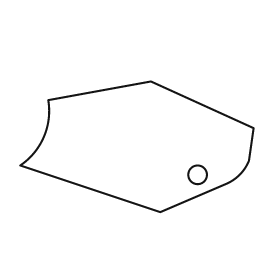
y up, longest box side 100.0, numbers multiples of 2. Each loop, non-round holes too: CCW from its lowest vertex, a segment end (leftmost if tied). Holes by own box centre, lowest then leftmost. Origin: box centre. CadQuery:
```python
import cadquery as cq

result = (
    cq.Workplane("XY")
    .moveTo(10.0, -28.0)
    .lineTo(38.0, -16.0)
    .threePointArc((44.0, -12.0), (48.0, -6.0))
    .lineTo(50.0, 8.0)
    .lineTo(6.0, 28.0)
    .lineTo(-38.0, 20.0)
    .threePointArc((-40.0, 4.0), (-50.0, -8.0))
    .close()
    .moveTo(26.0, -12.0)
    .circle(4.0)
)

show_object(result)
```